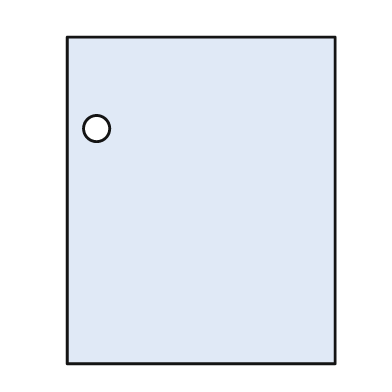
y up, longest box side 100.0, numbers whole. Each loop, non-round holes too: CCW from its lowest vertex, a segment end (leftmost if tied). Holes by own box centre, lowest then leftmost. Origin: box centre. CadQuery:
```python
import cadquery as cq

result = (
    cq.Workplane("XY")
    .moveTo(-41.0, -50.0)
    .lineTo(41.0, -50.0)
    .lineTo(41.0, 50.0)
    .lineTo(-41.0, 50.0)
    .close()
    .moveTo(-32.0, 22.0)
    .circle(4.0)
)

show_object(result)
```